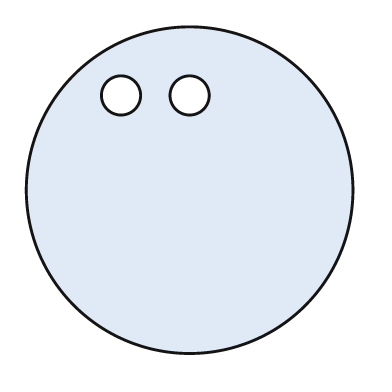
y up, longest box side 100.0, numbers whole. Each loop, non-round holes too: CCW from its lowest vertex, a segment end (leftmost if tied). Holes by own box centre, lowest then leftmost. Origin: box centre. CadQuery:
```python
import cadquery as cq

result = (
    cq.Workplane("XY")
    .moveTo(0.0, 0.0)
    .circle(50.0)
    .moveTo(-21.0, 29.0)
    .circle(6.0)
    .moveTo(0.0, 29.0)
    .circle(6.0)
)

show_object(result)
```